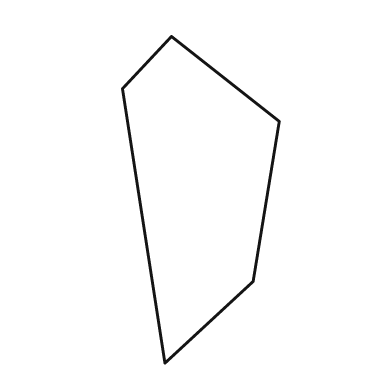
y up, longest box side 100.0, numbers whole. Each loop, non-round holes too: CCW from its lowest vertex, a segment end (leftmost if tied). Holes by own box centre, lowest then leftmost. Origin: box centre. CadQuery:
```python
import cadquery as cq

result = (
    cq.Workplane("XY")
    .moveTo(-11.0, -50.0)
    .lineTo(16.0, -25.0)
    .lineTo(24.0, 24.0)
    .lineTo(-9.0, 50.0)
    .lineTo(-24.0, 34.0)
    .close()
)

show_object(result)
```